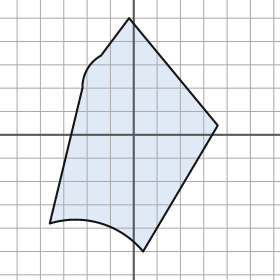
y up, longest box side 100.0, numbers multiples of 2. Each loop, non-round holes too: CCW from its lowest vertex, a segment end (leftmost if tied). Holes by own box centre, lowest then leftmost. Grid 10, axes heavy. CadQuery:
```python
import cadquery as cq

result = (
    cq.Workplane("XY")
    .moveTo(4.0, -50.0)
    .lineTo(36.0, 4.0)
    .lineTo(-2.0, 50.0)
    .lineTo(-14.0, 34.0)
    .threePointArc((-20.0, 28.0), (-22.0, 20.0))
    .lineTo(-36.0, -38.0)
    .threePointArc((-14.0, -38.0), (4.0, -50.0))
    .close()
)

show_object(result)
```